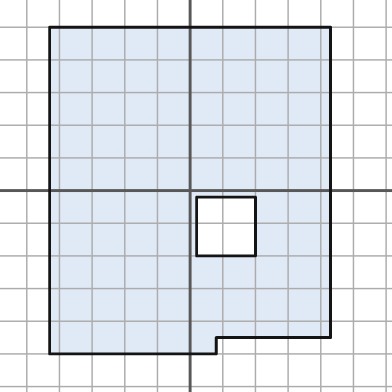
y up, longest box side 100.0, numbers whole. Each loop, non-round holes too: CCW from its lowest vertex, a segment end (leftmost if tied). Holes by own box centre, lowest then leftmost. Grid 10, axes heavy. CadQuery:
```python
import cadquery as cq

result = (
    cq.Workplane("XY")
    .moveTo(-43.0, -50.0)
    .lineTo(8.0, -50.0)
    .lineTo(8.0, -45.0)
    .lineTo(43.0, -45.0)
    .lineTo(43.0, 50.0)
    .lineTo(-43.0, 50.0)
    .close()
    .moveTo(2.0, -20.0)
    .lineTo(20.0, -20.0)
    .lineTo(20.0, -2.0)
    .lineTo(2.0, -2.0)
    .close()
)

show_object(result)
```